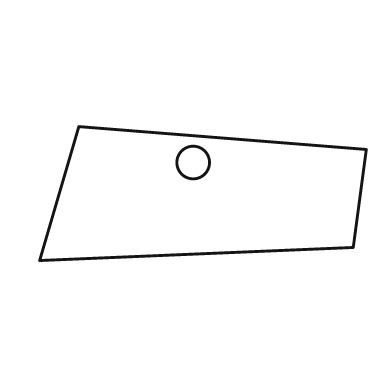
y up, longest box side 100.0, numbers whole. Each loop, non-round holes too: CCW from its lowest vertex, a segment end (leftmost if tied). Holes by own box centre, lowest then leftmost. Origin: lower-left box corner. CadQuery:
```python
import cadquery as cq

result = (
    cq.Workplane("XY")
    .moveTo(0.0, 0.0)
    .lineTo(96.0, 4.0)
    .lineTo(100.0, 34.0)
    .lineTo(12.0, 41.0)
    .close()
    .moveTo(47.0, 30.0)
    .circle(5.0)
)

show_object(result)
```